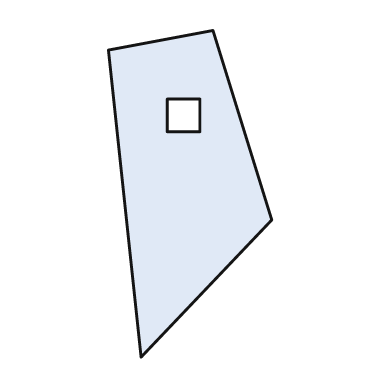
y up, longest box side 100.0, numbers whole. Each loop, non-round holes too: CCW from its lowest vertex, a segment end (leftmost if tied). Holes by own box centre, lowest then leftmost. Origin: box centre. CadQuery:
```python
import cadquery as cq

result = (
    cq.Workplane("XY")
    .moveTo(-15.0, -50.0)
    .lineTo(25.0, -8.0)
    .lineTo(7.0, 50.0)
    .lineTo(-25.0, 44.0)
    .close()
    .moveTo(-7.0, 19.0)
    .lineTo(3.0, 19.0)
    .lineTo(3.0, 29.0)
    .lineTo(-7.0, 29.0)
    .close()
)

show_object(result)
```